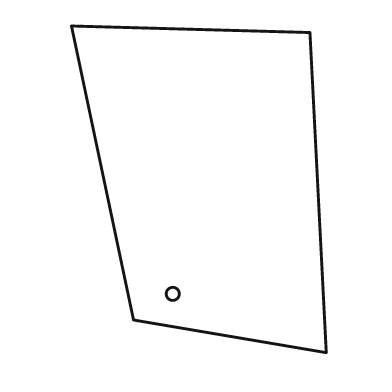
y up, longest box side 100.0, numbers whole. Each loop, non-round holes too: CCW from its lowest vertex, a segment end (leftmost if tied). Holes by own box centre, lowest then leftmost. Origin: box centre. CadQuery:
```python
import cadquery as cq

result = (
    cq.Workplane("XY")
    .moveTo(39.0, -50.0)
    .lineTo(34.0, 48.0)
    .lineTo(-39.0, 50.0)
    .lineTo(-20.0, -40.0)
    .close()
    .moveTo(-8.0, -32.0)
    .circle(2.0)
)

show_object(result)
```